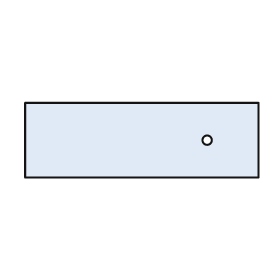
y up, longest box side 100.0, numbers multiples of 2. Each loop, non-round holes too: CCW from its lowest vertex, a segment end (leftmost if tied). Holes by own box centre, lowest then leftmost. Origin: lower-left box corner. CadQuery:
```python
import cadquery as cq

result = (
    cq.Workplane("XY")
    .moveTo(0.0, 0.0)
    .lineTo(100.0, 0.0)
    .lineTo(100.0, 32.0)
    .lineTo(0.0, 32.0)
    .close()
    .moveTo(78.0, 16.0)
    .circle(2.0)
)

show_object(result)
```